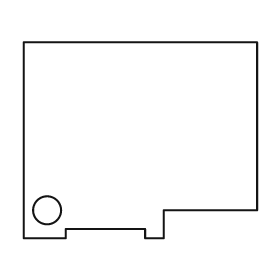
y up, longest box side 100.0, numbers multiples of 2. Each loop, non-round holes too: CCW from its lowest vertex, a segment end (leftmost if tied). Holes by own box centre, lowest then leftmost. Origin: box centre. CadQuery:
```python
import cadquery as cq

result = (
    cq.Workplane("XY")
    .moveTo(-50.0, -42.0)
    .lineTo(-32.0, -42.0)
    .lineTo(-32.0, -38.0)
    .lineTo(2.0, -38.0)
    .lineTo(2.0, -42.0)
    .lineTo(10.0, -42.0)
    .lineTo(10.0, -30.0)
    .lineTo(50.0, -30.0)
    .lineTo(50.0, 42.0)
    .lineTo(-50.0, 42.0)
    .close()
    .moveTo(-40.0, -30.0)
    .circle(6.0)
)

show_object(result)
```